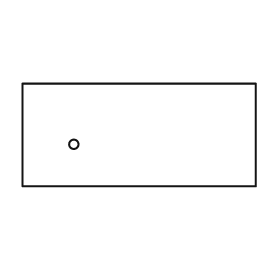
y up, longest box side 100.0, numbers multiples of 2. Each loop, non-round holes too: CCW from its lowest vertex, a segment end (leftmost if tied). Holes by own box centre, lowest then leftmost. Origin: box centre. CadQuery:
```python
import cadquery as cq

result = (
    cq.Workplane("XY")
    .moveTo(-50.0, -22.0)
    .lineTo(50.0, -22.0)
    .lineTo(50.0, 22.0)
    .lineTo(-50.0, 22.0)
    .close()
    .moveTo(-28.0, -4.0)
    .circle(2.0)
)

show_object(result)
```